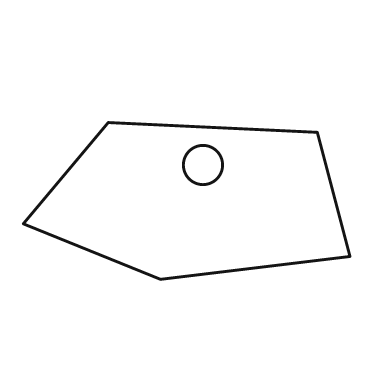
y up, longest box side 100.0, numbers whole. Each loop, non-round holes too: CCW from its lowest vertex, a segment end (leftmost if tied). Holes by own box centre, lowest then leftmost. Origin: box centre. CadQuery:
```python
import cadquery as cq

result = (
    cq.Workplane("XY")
    .moveTo(-8.0, -24.0)
    .lineTo(50.0, -17.0)
    .lineTo(40.0, 21.0)
    .lineTo(-24.0, 24.0)
    .lineTo(-50.0, -7.0)
    .close()
    .moveTo(5.0, 11.0)
    .circle(6.0)
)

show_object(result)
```